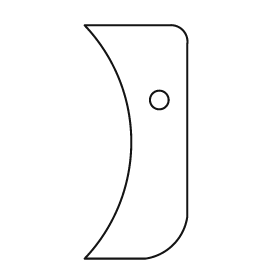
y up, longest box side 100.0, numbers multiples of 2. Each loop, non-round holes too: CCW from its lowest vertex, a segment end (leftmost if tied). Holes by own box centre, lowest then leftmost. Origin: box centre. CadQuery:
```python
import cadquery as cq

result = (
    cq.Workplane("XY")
    .moveTo(-22.0, -50.0)
    .lineTo(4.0, -50.0)
    .threePointArc((16.0, -44.0), (22.0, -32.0))
    .lineTo(22.0, 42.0)
    .threePointArc((20.0, 48.0), (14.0, 50.0))
    .lineTo(-22.0, 50.0)
    .threePointArc((-2.0, 0.0), (-22.0, -50.0))
    .close()
    .moveTo(10.0, 18.0)
    .circle(4.0)
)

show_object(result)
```